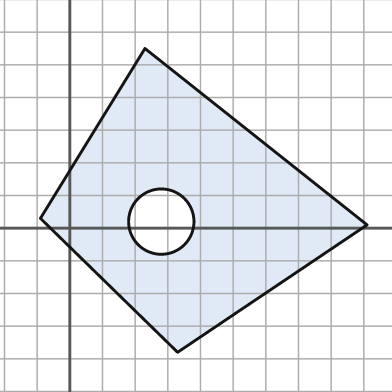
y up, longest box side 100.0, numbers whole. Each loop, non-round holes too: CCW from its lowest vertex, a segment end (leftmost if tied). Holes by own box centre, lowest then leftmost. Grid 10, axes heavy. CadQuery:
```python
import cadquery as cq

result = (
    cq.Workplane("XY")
    .moveTo(33.0, -38.0)
    .lineTo(91.0, 1.0)
    .lineTo(23.0, 55.0)
    .lineTo(-9.0, 3.0)
    .close()
    .moveTo(28.0, 2.0)
    .circle(10.0)
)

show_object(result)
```